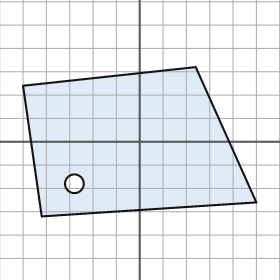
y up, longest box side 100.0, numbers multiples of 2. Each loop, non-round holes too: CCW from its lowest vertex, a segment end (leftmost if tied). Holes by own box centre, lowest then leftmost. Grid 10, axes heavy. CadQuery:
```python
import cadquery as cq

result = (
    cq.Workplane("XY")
    .moveTo(-42.0, -32.0)
    .lineTo(50.0, -26.0)
    .lineTo(24.0, 32.0)
    .lineTo(-50.0, 24.0)
    .close()
    .moveTo(-28.0, -18.0)
    .circle(4.0)
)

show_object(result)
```